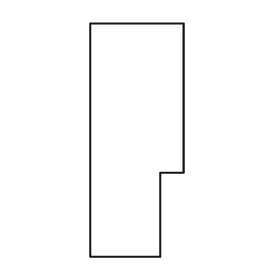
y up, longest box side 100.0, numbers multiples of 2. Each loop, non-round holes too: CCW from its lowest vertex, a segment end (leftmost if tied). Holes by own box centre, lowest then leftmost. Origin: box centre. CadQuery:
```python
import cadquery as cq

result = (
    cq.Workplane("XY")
    .moveTo(-20.0, -50.0)
    .lineTo(10.0, -50.0)
    .lineTo(10.0, -14.0)
    .lineTo(20.0, -14.0)
    .lineTo(20.0, 50.0)
    .lineTo(-20.0, 50.0)
    .close()
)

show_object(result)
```